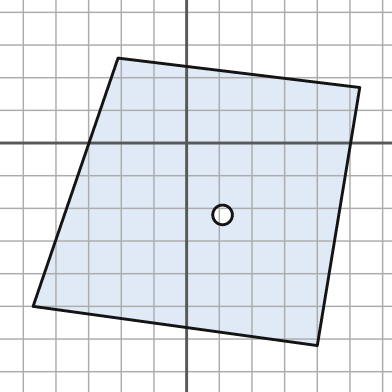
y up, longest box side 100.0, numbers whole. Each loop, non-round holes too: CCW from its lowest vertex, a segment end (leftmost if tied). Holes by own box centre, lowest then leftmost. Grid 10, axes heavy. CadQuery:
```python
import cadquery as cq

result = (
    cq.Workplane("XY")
    .moveTo(40.0, -62.0)
    .lineTo(53.0, 17.0)
    .lineTo(-21.0, 26.0)
    .lineTo(-47.0, -50.0)
    .close()
    .moveTo(11.0, -22.0)
    .circle(3.0)
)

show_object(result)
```